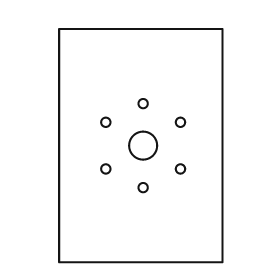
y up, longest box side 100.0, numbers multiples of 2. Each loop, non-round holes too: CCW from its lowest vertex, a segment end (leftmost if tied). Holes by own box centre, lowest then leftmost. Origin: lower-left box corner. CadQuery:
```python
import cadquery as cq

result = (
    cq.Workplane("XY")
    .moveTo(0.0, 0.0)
    .lineTo(70.0, 0.0)
    .lineTo(70.0, 100.0)
    .lineTo(0.0, 100.0)
    .close()
    .moveTo(36.0, 32.0)
    .circle(2.0)
    .moveTo(20.0, 40.0)
    .circle(2.0)
    .moveTo(52.0, 40.0)
    .circle(2.0)
    .moveTo(36.0, 50.0)
    .circle(6.0)
    .moveTo(20.0, 60.0)
    .circle(2.0)
    .moveTo(52.0, 60.0)
    .circle(2.0)
    .moveTo(36.0, 68.0)
    .circle(2.0)
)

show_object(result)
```